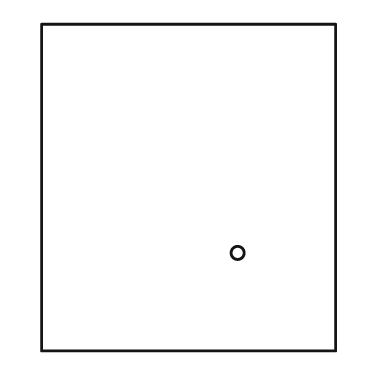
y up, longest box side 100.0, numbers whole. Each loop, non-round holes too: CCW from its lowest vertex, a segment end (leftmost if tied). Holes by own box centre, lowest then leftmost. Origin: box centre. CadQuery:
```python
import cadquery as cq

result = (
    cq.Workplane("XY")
    .moveTo(-45.0, -50.0)
    .lineTo(45.0, -50.0)
    .lineTo(45.0, 50.0)
    .lineTo(-45.0, 50.0)
    .close()
    .moveTo(15.0, -20.0)
    .circle(2.0)
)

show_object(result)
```